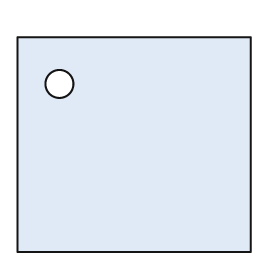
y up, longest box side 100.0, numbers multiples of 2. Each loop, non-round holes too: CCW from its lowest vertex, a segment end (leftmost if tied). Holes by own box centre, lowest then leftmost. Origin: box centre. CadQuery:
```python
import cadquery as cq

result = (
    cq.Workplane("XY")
    .moveTo(-50.0, -46.0)
    .lineTo(50.0, -46.0)
    .lineTo(50.0, 46.0)
    .lineTo(-50.0, 46.0)
    .close()
    .moveTo(-32.0, 26.0)
    .circle(6.0)
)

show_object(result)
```